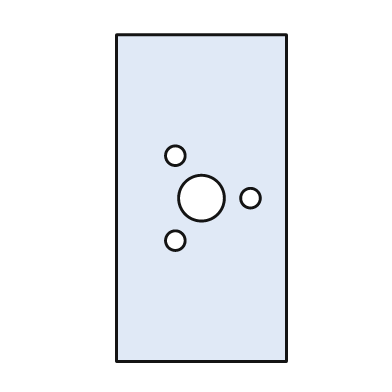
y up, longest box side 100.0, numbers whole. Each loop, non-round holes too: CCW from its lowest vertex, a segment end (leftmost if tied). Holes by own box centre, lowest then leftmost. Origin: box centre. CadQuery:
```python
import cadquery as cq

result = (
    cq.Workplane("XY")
    .moveTo(-26.0, -50.0)
    .lineTo(26.0, -50.0)
    .lineTo(26.0, 50.0)
    .lineTo(-26.0, 50.0)
    .close()
    .moveTo(-8.0, -13.0)
    .circle(3.0)
    .moveTo(0.0, 0.0)
    .circle(7.0)
    .moveTo(15.0, 0.0)
    .circle(3.0)
    .moveTo(-8.0, 13.0)
    .circle(3.0)
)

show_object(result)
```